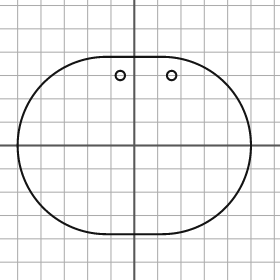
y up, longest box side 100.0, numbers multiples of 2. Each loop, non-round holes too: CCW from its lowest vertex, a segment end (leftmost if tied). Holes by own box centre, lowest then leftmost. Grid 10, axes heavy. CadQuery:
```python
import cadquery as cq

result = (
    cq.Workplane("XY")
    .moveTo(-12.0, -38.0)
    .lineTo(12.0, -38.0)
    .threePointArc((50.0, 0.0), (12.0, 38.0))
    .lineTo(-12.0, 38.0)
    .threePointArc((-50.0, 0.0), (-12.0, -38.0))
    .close()
    .moveTo(-6.0, 30.0)
    .circle(2.0)
    .moveTo(16.0, 30.0)
    .circle(2.0)
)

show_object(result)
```